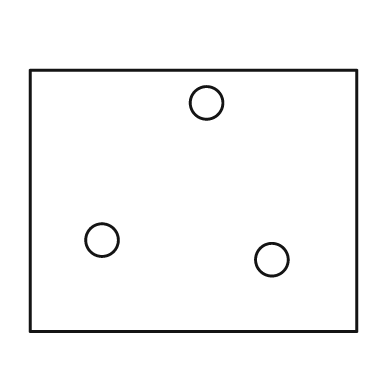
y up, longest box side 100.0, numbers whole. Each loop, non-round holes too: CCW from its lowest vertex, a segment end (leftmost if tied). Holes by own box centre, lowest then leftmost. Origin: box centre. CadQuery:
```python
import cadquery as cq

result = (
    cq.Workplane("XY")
    .moveTo(-50.0, -40.0)
    .lineTo(50.0, -40.0)
    .lineTo(50.0, 40.0)
    .lineTo(-50.0, 40.0)
    .close()
    .moveTo(24.0, -18.0)
    .circle(5.0)
    .moveTo(-28.0, -12.0)
    .circle(5.0)
    .moveTo(4.0, 30.0)
    .circle(5.0)
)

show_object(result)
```